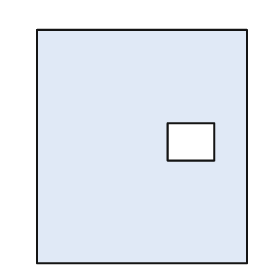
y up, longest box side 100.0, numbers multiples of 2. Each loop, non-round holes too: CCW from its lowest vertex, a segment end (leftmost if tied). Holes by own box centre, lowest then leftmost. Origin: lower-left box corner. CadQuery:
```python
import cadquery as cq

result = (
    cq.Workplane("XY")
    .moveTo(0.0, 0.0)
    .lineTo(90.0, 0.0)
    .lineTo(90.0, 100.0)
    .lineTo(0.0, 100.0)
    .close()
    .moveTo(56.0, 44.0)
    .lineTo(76.0, 44.0)
    .lineTo(76.0, 60.0)
    .lineTo(56.0, 60.0)
    .close()
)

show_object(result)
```